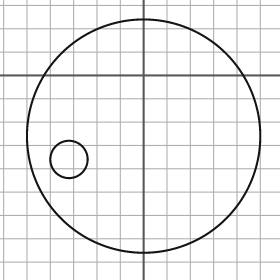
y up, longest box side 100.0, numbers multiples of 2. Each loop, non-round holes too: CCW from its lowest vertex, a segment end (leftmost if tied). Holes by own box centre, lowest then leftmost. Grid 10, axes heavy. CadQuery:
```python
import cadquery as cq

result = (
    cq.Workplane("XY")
    .moveTo(0.0, -26.0)
    .circle(50.0)
    .moveTo(-32.0, -36.0)
    .circle(8.0)
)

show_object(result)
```